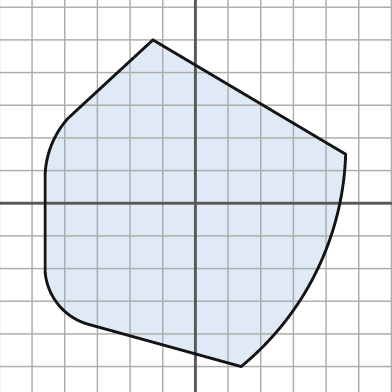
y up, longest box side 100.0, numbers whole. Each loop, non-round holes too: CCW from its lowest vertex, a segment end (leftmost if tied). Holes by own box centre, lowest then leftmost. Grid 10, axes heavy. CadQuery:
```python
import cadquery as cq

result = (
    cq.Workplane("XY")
    .moveTo(14.0, -50.0)
    .threePointArc((37.0, -21.0), (46.0, 15.0))
    .lineTo(-13.0, 50.0)
    .lineTo(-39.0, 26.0)
    .threePointArc((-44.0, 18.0), (-46.0, 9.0))
    .lineTo(-46.0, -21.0)
    .threePointArc((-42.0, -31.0), (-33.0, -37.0))
    .close()
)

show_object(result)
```